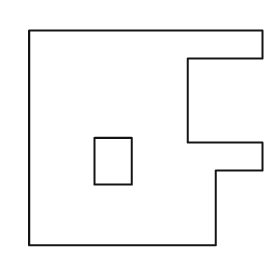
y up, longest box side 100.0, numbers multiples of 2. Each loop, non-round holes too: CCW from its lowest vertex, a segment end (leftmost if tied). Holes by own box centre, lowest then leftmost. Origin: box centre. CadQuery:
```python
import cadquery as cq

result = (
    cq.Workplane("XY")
    .moveTo(-50.0, -46.0)
    .lineTo(30.0, -46.0)
    .lineTo(30.0, -14.0)
    .lineTo(50.0, -14.0)
    .lineTo(50.0, -2.0)
    .lineTo(18.0, -2.0)
    .lineTo(18.0, 34.0)
    .lineTo(50.0, 34.0)
    .lineTo(50.0, 46.0)
    .lineTo(-50.0, 46.0)
    .close()
    .moveTo(-22.0, -20.0)
    .lineTo(-6.0, -20.0)
    .lineTo(-6.0, 0.0)
    .lineTo(-22.0, 0.0)
    .close()
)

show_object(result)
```